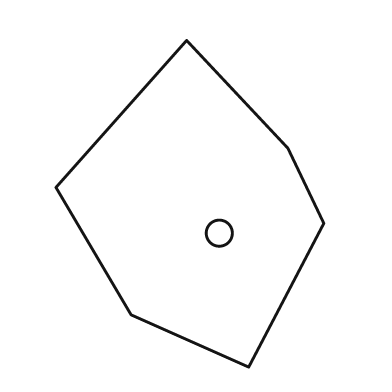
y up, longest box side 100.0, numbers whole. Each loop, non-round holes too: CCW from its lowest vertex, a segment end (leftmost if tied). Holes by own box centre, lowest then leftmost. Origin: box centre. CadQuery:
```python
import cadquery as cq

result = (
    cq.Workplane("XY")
    .moveTo(18.0, -50.0)
    .lineTo(41.0, -6.0)
    .lineTo(30.0, 17.0)
    .lineTo(-1.0, 50.0)
    .lineTo(-41.0, 5.0)
    .lineTo(-18.0, -34.0)
    .close()
    .moveTo(9.0, -9.0)
    .circle(4.0)
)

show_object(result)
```